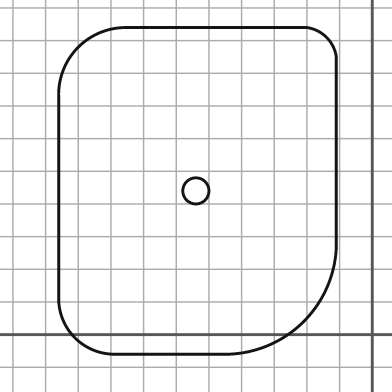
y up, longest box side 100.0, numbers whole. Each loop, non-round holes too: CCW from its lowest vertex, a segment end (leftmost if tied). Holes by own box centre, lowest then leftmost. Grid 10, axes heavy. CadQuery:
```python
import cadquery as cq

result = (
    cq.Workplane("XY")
    .moveTo(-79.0, -6.0)
    .lineTo(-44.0, -6.0)
    .threePointArc((-21.0, 4.0), (-11.0, 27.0))
    .lineTo(-11.0, 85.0)
    .threePointArc((-14.0, 91.0), (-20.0, 94.0))
    .lineTo(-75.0, 94.0)
    .threePointArc((-90.0, 88.0), (-96.0, 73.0))
    .lineTo(-96.0, 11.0)
    .threePointArc((-91.0, -1.0), (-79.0, -6.0))
    .close()
    .moveTo(-54.0, 44.0)
    .circle(4.0)
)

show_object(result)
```